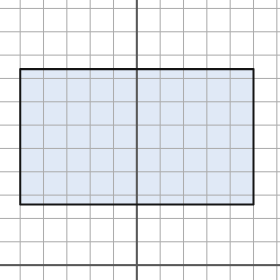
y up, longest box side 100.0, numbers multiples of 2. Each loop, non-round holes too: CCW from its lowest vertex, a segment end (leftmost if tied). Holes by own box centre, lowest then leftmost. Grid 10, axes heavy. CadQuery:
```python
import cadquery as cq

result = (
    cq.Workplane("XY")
    .moveTo(-50.0, 26.0)
    .lineTo(50.0, 26.0)
    .lineTo(50.0, 84.0)
    .lineTo(-50.0, 84.0)
    .close()
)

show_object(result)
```